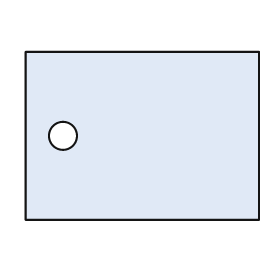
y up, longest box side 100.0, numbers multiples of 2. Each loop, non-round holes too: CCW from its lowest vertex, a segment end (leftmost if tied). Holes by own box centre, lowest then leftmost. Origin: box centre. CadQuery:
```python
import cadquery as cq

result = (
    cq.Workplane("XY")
    .moveTo(-50.0, -36.0)
    .lineTo(50.0, -36.0)
    .lineTo(50.0, 36.0)
    .lineTo(-50.0, 36.0)
    .close()
    .moveTo(-34.0, 0.0)
    .circle(6.0)
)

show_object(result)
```